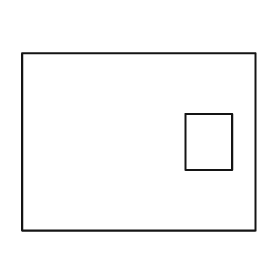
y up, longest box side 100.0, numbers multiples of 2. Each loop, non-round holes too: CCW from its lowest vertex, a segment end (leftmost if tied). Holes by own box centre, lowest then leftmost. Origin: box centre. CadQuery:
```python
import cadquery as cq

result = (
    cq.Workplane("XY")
    .moveTo(-50.0, -38.0)
    .lineTo(50.0, -38.0)
    .lineTo(50.0, 38.0)
    .lineTo(-50.0, 38.0)
    .close()
    .moveTo(20.0, -12.0)
    .lineTo(40.0, -12.0)
    .lineTo(40.0, 12.0)
    .lineTo(20.0, 12.0)
    .close()
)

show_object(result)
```